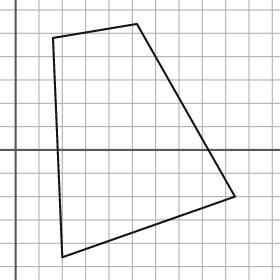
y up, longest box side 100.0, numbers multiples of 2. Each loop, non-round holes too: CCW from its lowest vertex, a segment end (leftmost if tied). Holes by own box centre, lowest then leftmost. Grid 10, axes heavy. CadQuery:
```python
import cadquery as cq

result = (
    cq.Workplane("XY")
    .moveTo(20.0, -46.0)
    .lineTo(94.0, -20.0)
    .lineTo(52.0, 54.0)
    .lineTo(16.0, 48.0)
    .close()
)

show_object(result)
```